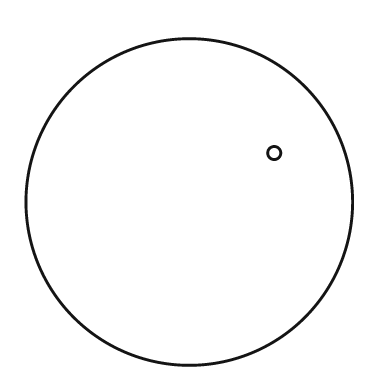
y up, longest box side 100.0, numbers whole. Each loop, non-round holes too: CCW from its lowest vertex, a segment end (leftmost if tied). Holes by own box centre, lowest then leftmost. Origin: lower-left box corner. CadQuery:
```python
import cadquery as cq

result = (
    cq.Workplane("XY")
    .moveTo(50.0, 50.0)
    .circle(50.0)
    .moveTo(76.0, 65.0)
    .circle(2.0)
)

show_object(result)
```